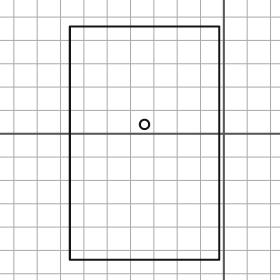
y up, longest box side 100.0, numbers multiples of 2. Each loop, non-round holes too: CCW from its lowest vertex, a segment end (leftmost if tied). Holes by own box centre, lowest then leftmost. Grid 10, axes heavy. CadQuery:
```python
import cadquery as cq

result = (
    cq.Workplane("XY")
    .moveTo(-66.0, -54.0)
    .lineTo(-2.0, -54.0)
    .lineTo(-2.0, 46.0)
    .lineTo(-66.0, 46.0)
    .close()
    .moveTo(-34.0, 4.0)
    .circle(2.0)
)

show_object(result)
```